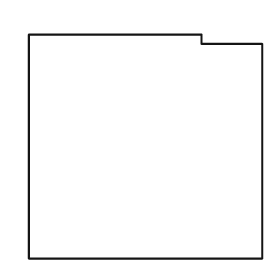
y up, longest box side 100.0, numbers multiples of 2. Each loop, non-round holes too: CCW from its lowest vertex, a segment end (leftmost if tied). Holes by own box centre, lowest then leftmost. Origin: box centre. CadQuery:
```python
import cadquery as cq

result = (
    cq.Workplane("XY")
    .moveTo(-50.0, -48.0)
    .lineTo(50.0, -48.0)
    .lineTo(50.0, 44.0)
    .lineTo(24.0, 44.0)
    .lineTo(24.0, 48.0)
    .lineTo(-50.0, 48.0)
    .close()
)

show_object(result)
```